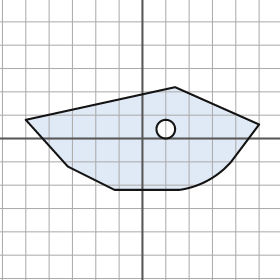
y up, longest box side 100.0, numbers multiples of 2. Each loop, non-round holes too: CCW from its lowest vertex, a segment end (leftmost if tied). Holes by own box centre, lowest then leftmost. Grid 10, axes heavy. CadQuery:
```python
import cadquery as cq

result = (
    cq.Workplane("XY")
    .moveTo(-12.0, -22.0)
    .lineTo(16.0, -22.0)
    .threePointArc((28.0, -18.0), (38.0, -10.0))
    .lineTo(50.0, 6.0)
    .lineTo(14.0, 22.0)
    .lineTo(-50.0, 8.0)
    .lineTo(-32.0, -12.0)
    .close()
    .moveTo(10.0, 4.0)
    .circle(4.0)
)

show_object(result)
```